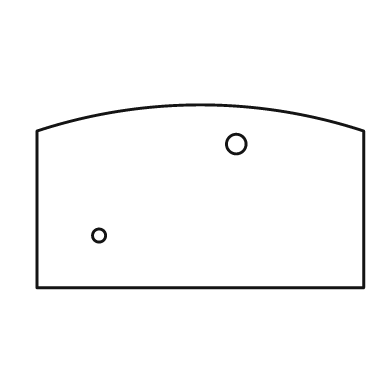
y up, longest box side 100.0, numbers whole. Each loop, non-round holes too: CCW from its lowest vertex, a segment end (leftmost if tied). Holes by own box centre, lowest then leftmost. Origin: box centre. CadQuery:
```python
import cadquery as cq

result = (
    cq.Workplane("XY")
    .moveTo(-50.0, -28.0)
    .lineTo(50.0, -28.0)
    .lineTo(50.0, 20.0)
    .threePointArc((0.0, 28.0), (-50.0, 20.0))
    .close()
    .moveTo(-31.0, -12.0)
    .circle(2.0)
    .moveTo(11.0, 16.0)
    .circle(3.0)
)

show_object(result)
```